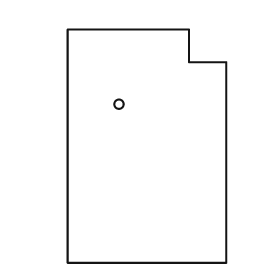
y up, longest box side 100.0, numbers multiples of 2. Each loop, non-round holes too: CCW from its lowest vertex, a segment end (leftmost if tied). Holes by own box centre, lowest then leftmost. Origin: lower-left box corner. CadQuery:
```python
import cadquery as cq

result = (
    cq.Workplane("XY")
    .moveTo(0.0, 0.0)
    .lineTo(68.0, 0.0)
    .lineTo(68.0, 86.0)
    .lineTo(52.0, 86.0)
    .lineTo(52.0, 100.0)
    .lineTo(0.0, 100.0)
    .close()
    .moveTo(22.0, 68.0)
    .circle(2.0)
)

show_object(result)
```